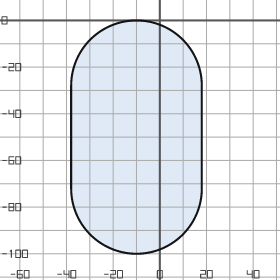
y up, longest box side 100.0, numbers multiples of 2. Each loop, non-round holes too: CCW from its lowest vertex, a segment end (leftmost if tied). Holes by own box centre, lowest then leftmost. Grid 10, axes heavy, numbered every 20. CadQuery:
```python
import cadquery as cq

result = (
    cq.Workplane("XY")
    .moveTo(-38.0, -72.0)
    .threePointArc((-10.0, -100.0), (18.0, -72.0))
    .lineTo(18.0, -28.0)
    .threePointArc((-10.0, 0.0), (-38.0, -28.0))
    .close()
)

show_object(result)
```